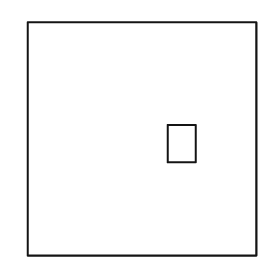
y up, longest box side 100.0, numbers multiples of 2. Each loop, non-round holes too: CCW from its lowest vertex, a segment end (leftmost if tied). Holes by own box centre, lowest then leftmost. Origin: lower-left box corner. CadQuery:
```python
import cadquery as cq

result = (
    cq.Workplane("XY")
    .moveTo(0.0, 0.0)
    .lineTo(98.0, 0.0)
    .lineTo(98.0, 100.0)
    .lineTo(0.0, 100.0)
    .close()
    .moveTo(60.0, 40.0)
    .lineTo(72.0, 40.0)
    .lineTo(72.0, 56.0)
    .lineTo(60.0, 56.0)
    .close()
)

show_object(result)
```